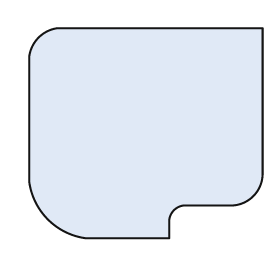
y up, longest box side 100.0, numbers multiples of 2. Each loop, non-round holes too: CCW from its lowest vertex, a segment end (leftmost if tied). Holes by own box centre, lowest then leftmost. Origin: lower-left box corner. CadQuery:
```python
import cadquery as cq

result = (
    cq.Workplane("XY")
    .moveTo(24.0, 0.0)
    .lineTo(60.0, 0.0)
    .lineTo(60.0, 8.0)
    .threePointArc((62.0, 12.0), (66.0, 14.0))
    .lineTo(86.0, 14.0)
    .threePointArc((96.0, 18.0), (100.0, 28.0))
    .lineTo(100.0, 90.0)
    .lineTo(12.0, 90.0)
    .threePointArc((4.0, 86.0), (0.0, 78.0))
    .lineTo(0.0, 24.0)
    .threePointArc((8.0, 8.0), (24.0, 0.0))
    .close()
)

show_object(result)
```